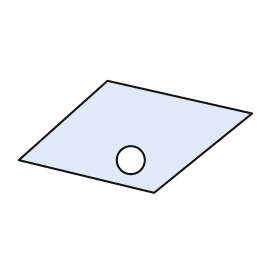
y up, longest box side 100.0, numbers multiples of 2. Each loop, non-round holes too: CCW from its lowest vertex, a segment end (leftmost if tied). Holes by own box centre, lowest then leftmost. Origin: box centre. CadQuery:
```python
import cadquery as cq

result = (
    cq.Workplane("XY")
    .moveTo(8.0, -24.0)
    .lineTo(50.0, 10.0)
    .lineTo(-12.0, 24.0)
    .lineTo(-50.0, -10.0)
    .close()
    .moveTo(-2.0, -10.0)
    .circle(6.0)
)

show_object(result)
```